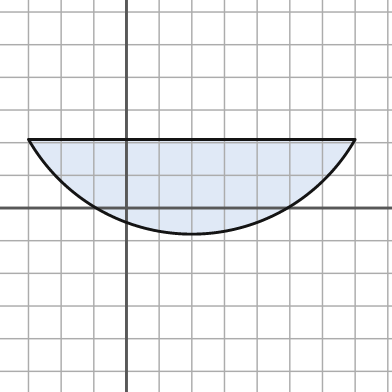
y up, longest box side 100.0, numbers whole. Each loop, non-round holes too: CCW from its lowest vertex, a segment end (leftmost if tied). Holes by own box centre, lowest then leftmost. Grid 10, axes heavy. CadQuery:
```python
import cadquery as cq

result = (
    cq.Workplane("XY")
    .moveTo(-30.0, 21.0)
    .threePointArc((20.0, -8.0), (70.0, 21.0))
    .close()
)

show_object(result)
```